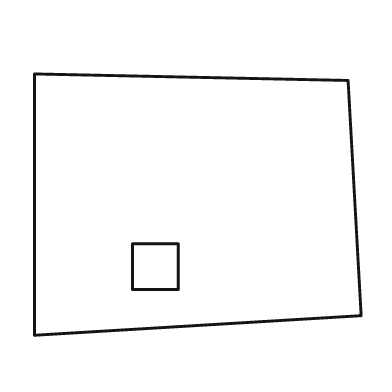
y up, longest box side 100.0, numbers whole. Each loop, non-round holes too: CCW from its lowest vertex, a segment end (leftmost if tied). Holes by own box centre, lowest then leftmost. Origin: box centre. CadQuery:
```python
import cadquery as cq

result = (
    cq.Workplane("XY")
    .moveTo(-50.0, -40.0)
    .lineTo(50.0, -34.0)
    .lineTo(46.0, 38.0)
    .lineTo(-50.0, 40.0)
    .close()
    .moveTo(-20.0, -26.0)
    .lineTo(-6.0, -26.0)
    .lineTo(-6.0, -12.0)
    .lineTo(-20.0, -12.0)
    .close()
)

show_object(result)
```